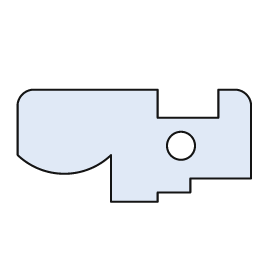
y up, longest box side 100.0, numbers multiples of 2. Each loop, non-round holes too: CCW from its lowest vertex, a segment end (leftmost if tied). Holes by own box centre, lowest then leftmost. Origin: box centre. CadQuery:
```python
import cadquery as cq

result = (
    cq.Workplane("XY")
    .moveTo(-10.0, -24.0)
    .lineTo(10.0, -24.0)
    .lineTo(10.0, -20.0)
    .lineTo(24.0, -20.0)
    .lineTo(24.0, -14.0)
    .lineTo(50.0, -14.0)
    .lineTo(50.0, 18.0)
    .threePointArc((48.0, 22.0), (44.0, 24.0))
    .lineTo(36.0, 24.0)
    .lineTo(36.0, 12.0)
    .lineTo(10.0, 12.0)
    .lineTo(10.0, 24.0)
    .lineTo(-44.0, 24.0)
    .threePointArc((-48.0, 22.0), (-50.0, 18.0))
    .lineTo(-50.0, -4.0)
    .threePointArc((-30.0, -12.0), (-10.0, -4.0))
    .close()
    .moveTo(20.0, 0.0)
    .circle(6.0)
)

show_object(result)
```